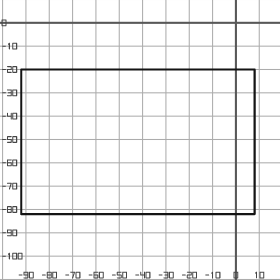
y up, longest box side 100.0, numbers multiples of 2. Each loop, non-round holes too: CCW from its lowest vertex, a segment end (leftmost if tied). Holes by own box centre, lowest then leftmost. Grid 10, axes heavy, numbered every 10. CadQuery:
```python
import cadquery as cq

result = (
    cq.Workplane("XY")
    .moveTo(-92.0, -82.0)
    .lineTo(8.0, -82.0)
    .lineTo(8.0, -20.0)
    .lineTo(-92.0, -20.0)
    .close()
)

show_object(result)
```